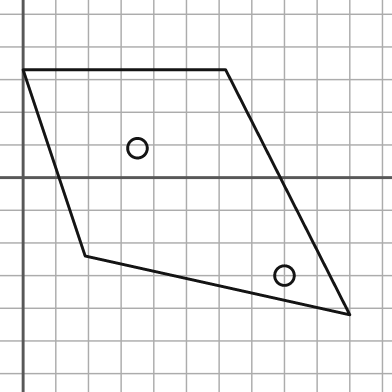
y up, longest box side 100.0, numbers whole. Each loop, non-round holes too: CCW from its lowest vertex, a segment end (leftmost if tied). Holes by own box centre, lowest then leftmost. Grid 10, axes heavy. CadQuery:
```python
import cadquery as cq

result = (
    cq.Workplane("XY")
    .moveTo(100.0, -42.0)
    .lineTo(62.0, 33.0)
    .lineTo(0.0, 33.0)
    .lineTo(19.0, -24.0)
    .close()
    .moveTo(80.0, -30.0)
    .circle(3.0)
    .moveTo(35.0, 9.0)
    .circle(3.0)
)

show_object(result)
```